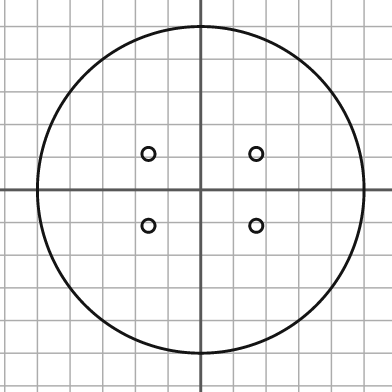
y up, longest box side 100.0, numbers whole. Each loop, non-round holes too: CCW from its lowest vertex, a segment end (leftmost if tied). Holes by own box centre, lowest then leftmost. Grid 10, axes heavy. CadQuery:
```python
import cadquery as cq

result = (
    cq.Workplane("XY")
    .moveTo(0.0, 0.0)
    .circle(50.0)
    .moveTo(-16.0, -11.0)
    .circle(2.0)
    .moveTo(17.0, -11.0)
    .circle(2.0)
    .moveTo(-16.0, 11.0)
    .circle(2.0)
    .moveTo(17.0, 11.0)
    .circle(2.0)
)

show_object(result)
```